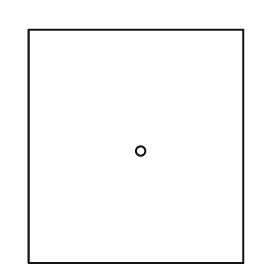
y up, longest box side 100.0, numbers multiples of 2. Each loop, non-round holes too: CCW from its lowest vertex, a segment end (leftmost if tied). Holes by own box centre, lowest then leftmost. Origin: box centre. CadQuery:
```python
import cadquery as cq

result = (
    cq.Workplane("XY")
    .moveTo(-46.0, -50.0)
    .lineTo(46.0, -50.0)
    .lineTo(46.0, 50.0)
    .lineTo(-46.0, 50.0)
    .close()
    .moveTo(2.0, -2.0)
    .circle(2.0)
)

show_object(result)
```